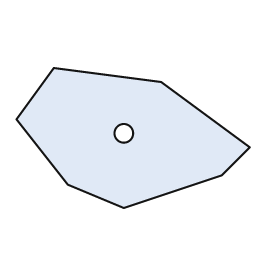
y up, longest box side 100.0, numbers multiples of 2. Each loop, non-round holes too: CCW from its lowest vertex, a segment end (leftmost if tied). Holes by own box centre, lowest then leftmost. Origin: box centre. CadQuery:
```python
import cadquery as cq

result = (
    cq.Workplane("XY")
    .moveTo(-4.0, -30.0)
    .lineTo(38.0, -16.0)
    .lineTo(50.0, -4.0)
    .lineTo(12.0, 24.0)
    .lineTo(-34.0, 30.0)
    .lineTo(-50.0, 8.0)
    .lineTo(-28.0, -20.0)
    .close()
    .moveTo(-4.0, 2.0)
    .circle(4.0)
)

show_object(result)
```